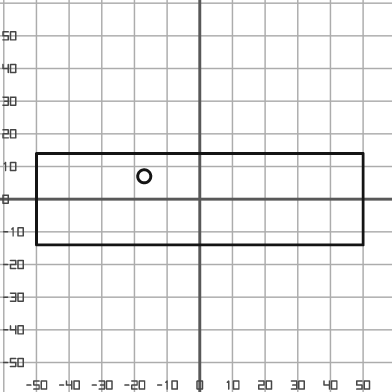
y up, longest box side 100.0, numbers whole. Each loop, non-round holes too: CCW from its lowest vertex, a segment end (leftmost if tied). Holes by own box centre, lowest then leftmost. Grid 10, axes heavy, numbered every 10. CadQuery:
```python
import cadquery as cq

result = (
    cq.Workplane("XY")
    .moveTo(-50.0, -14.0)
    .lineTo(50.0, -14.0)
    .lineTo(50.0, 14.0)
    .lineTo(-50.0, 14.0)
    .close()
    .moveTo(-17.0, 7.0)
    .circle(2.0)
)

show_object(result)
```